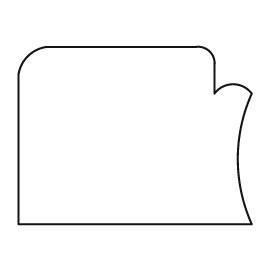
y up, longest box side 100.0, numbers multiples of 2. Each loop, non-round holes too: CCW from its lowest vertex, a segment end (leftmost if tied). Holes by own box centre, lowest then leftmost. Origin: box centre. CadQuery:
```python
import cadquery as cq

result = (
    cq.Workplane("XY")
    .moveTo(-50.0, -38.0)
    .lineTo(50.0, -38.0)
    .threePointArc((44.0, -10.0), (50.0, 18.0))
    .threePointArc((42.0, 22.0), (34.0, 18.0))
    .lineTo(34.0, 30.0)
    .threePointArc((32.0, 36.0), (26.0, 38.0))
    .lineTo(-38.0, 38.0)
    .threePointArc((-46.0, 34.0), (-50.0, 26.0))
    .close()
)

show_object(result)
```